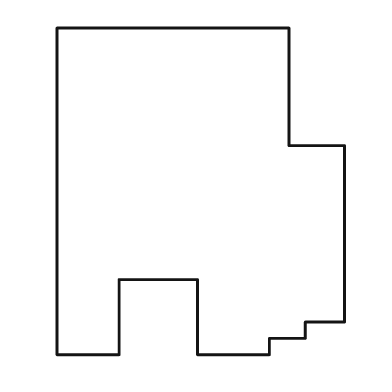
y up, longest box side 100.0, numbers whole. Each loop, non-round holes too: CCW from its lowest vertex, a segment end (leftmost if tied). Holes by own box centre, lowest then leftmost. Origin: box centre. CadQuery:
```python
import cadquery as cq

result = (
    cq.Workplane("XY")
    .moveTo(-44.0, -50.0)
    .lineTo(-25.0, -50.0)
    .lineTo(-25.0, -27.0)
    .lineTo(-1.0, -27.0)
    .lineTo(-1.0, -50.0)
    .lineTo(21.0, -50.0)
    .lineTo(21.0, -45.0)
    .lineTo(32.0, -45.0)
    .lineTo(32.0, -40.0)
    .lineTo(44.0, -40.0)
    .lineTo(44.0, 14.0)
    .lineTo(27.0, 14.0)
    .lineTo(27.0, 50.0)
    .lineTo(-44.0, 50.0)
    .close()
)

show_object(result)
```